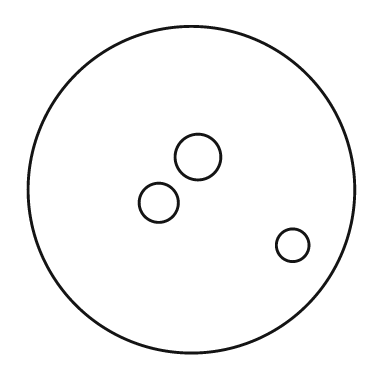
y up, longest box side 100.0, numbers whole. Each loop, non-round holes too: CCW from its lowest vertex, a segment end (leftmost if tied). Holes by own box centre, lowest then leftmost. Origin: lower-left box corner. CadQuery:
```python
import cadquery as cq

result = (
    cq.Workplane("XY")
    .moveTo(50.0, 50.0)
    .circle(50.0)
    .moveTo(81.0, 33.0)
    .circle(5.0)
    .moveTo(40.0, 46.0)
    .circle(6.0)
    .moveTo(52.0, 60.0)
    .circle(7.0)
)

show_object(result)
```